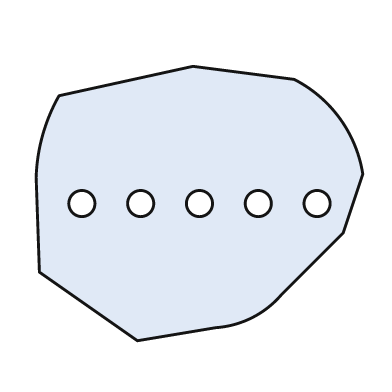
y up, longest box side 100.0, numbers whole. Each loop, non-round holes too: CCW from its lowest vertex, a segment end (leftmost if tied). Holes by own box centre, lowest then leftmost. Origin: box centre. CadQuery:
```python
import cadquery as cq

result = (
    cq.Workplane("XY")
    .moveTo(-19.0, -42.0)
    .lineTo(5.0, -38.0)
    .threePointArc((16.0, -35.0), (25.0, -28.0))
    .lineTo(44.0, -9.0)
    .lineTo(50.0, 9.0)
    .threePointArc((43.0, 26.0), (29.0, 38.0))
    .lineTo(-2.0, 42.0)
    .lineTo(-43.0, 33.0)
    .threePointArc((-48.0, 21.0), (-50.0, 8.0))
    .lineTo(-49.0, -21.0)
    .close()
    .moveTo(-36.0, 0.0)
    .circle(4.0)
    .moveTo(-18.0, 0.0)
    .circle(4.0)
    .moveTo(0.0, 0.0)
    .circle(4.0)
    .moveTo(18.0, 0.0)
    .circle(4.0)
    .moveTo(36.0, 0.0)
    .circle(4.0)
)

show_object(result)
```